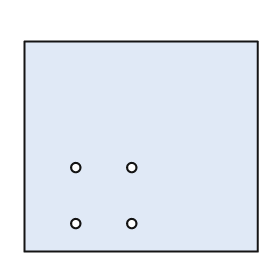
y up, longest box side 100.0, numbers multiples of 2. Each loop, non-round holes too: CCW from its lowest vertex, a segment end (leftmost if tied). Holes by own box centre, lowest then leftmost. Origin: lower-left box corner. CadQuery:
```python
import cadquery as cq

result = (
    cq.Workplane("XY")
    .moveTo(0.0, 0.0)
    .lineTo(100.0, 0.0)
    .lineTo(100.0, 90.0)
    .lineTo(0.0, 90.0)
    .close()
    .moveTo(22.0, 12.0)
    .circle(2.0)
    .moveTo(46.0, 12.0)
    .circle(2.0)
    .moveTo(22.0, 36.0)
    .circle(2.0)
    .moveTo(46.0, 36.0)
    .circle(2.0)
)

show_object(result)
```